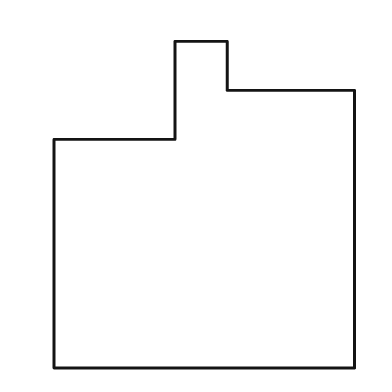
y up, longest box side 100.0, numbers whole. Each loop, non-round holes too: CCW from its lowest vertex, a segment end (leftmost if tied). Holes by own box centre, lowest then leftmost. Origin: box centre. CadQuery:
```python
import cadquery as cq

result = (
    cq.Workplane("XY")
    .moveTo(-46.0, -50.0)
    .lineTo(46.0, -50.0)
    .lineTo(46.0, 35.0)
    .lineTo(7.0, 35.0)
    .lineTo(7.0, 50.0)
    .lineTo(-9.0, 50.0)
    .lineTo(-9.0, 20.0)
    .lineTo(-46.0, 20.0)
    .close()
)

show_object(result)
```